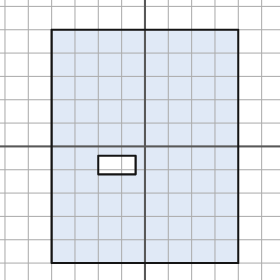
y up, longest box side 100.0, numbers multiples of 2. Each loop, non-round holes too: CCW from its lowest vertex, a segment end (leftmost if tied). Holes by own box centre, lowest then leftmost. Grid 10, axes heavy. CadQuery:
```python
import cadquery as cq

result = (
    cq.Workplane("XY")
    .moveTo(-40.0, -50.0)
    .lineTo(40.0, -50.0)
    .lineTo(40.0, 50.0)
    .lineTo(-40.0, 50.0)
    .close()
    .moveTo(-20.0, -12.0)
    .lineTo(-4.0, -12.0)
    .lineTo(-4.0, -4.0)
    .lineTo(-20.0, -4.0)
    .close()
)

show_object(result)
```